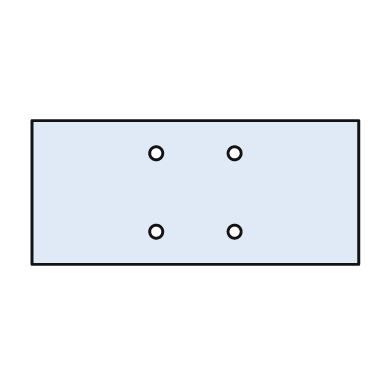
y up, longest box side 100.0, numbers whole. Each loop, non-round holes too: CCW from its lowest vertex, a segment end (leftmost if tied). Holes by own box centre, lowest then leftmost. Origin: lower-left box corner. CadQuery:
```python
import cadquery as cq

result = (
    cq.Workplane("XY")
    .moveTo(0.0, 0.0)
    .lineTo(100.0, 0.0)
    .lineTo(100.0, 44.0)
    .lineTo(0.0, 44.0)
    .close()
    .moveTo(38.0, 10.0)
    .circle(2.0)
    .moveTo(62.0, 10.0)
    .circle(2.0)
    .moveTo(38.0, 34.0)
    .circle(2.0)
    .moveTo(62.0, 34.0)
    .circle(2.0)
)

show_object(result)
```